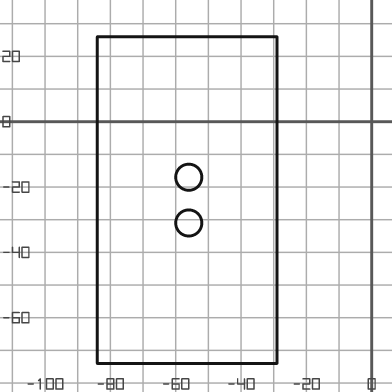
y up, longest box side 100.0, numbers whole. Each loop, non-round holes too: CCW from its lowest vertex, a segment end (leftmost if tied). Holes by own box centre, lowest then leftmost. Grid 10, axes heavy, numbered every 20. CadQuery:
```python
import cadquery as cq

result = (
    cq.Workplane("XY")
    .moveTo(-84.0, -74.0)
    .lineTo(-29.0, -74.0)
    .lineTo(-29.0, 26.0)
    .lineTo(-84.0, 26.0)
    .close()
    .moveTo(-56.0, -31.0)
    .circle(4.0)
    .moveTo(-56.0, -17.0)
    .circle(4.0)
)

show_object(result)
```